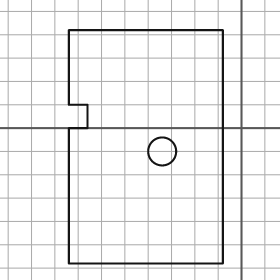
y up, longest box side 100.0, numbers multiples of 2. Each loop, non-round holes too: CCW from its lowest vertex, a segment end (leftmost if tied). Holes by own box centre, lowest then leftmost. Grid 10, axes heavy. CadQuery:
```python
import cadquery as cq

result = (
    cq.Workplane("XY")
    .moveTo(-74.0, -58.0)
    .lineTo(-8.0, -58.0)
    .lineTo(-8.0, 42.0)
    .lineTo(-74.0, 42.0)
    .lineTo(-74.0, 10.0)
    .lineTo(-66.0, 10.0)
    .lineTo(-66.0, 0.0)
    .lineTo(-74.0, 0.0)
    .close()
    .moveTo(-34.0, -10.0)
    .circle(6.0)
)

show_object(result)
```